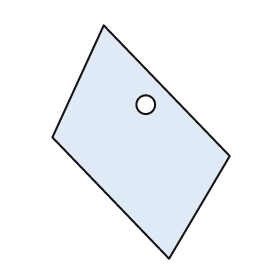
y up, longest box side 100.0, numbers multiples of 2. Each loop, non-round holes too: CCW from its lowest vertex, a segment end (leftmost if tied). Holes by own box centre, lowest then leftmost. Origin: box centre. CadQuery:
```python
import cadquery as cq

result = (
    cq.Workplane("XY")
    .moveTo(12.0, -50.0)
    .lineTo(38.0, -6.0)
    .lineTo(-16.0, 50.0)
    .lineTo(-38.0, 2.0)
    .close()
    .moveTo(2.0, 16.0)
    .circle(4.0)
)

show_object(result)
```